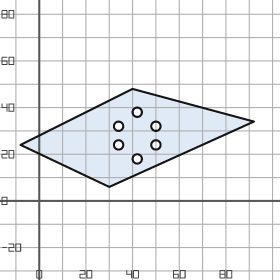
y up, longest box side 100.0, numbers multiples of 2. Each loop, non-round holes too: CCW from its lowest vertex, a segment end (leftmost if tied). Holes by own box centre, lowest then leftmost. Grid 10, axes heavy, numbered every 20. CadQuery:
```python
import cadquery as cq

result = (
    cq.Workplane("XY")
    .moveTo(30.0, 6.0)
    .lineTo(92.0, 34.0)
    .lineTo(40.0, 48.0)
    .lineTo(-8.0, 24.0)
    .close()
    .moveTo(42.0, 18.0)
    .circle(2.0)
    .moveTo(34.0, 24.0)
    .circle(2.0)
    .moveTo(50.0, 24.0)
    .circle(2.0)
    .moveTo(34.0, 32.0)
    .circle(2.0)
    .moveTo(50.0, 32.0)
    .circle(2.0)
    .moveTo(42.0, 38.0)
    .circle(2.0)
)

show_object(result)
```